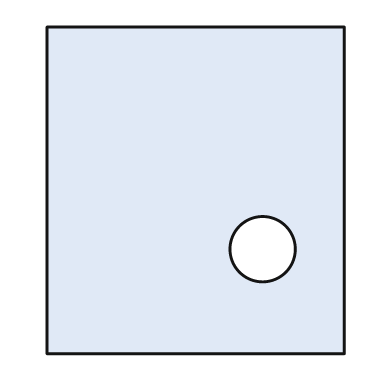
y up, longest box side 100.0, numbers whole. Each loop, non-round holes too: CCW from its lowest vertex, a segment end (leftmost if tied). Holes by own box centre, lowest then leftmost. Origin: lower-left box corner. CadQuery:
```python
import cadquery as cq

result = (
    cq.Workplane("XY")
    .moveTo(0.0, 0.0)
    .lineTo(91.0, 0.0)
    .lineTo(91.0, 100.0)
    .lineTo(0.0, 100.0)
    .close()
    .moveTo(66.0, 32.0)
    .circle(10.0)
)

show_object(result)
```